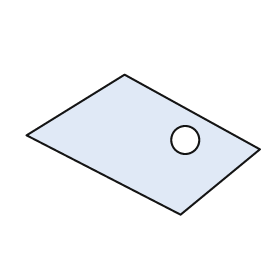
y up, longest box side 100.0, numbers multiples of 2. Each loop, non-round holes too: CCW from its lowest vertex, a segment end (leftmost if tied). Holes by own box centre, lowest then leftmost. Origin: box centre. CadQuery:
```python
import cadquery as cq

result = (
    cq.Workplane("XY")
    .moveTo(16.0, -30.0)
    .lineTo(50.0, -2.0)
    .lineTo(-8.0, 30.0)
    .lineTo(-50.0, 4.0)
    .close()
    .moveTo(18.0, 2.0)
    .circle(6.0)
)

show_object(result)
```